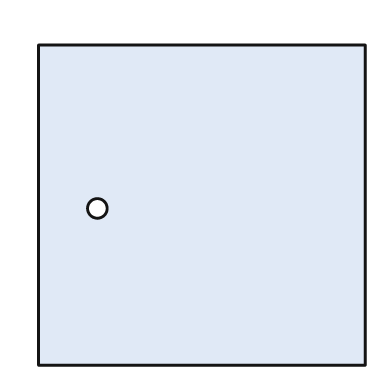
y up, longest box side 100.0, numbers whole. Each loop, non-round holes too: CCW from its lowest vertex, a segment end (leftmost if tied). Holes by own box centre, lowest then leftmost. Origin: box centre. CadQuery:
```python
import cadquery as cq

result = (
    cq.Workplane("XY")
    .moveTo(-50.0, -49.0)
    .lineTo(50.0, -49.0)
    .lineTo(50.0, 49.0)
    .lineTo(-50.0, 49.0)
    .close()
    .moveTo(-32.0, -1.0)
    .circle(3.0)
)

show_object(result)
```